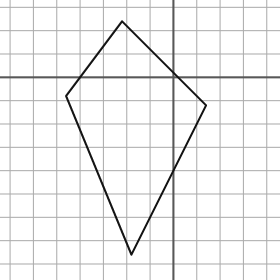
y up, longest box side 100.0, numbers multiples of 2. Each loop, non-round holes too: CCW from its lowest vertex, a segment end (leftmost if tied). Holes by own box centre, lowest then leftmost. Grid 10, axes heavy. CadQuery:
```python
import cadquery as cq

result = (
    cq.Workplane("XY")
    .moveTo(-18.0, -76.0)
    .lineTo(14.0, -12.0)
    .lineTo(-22.0, 24.0)
    .lineTo(-46.0, -8.0)
    .close()
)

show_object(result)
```